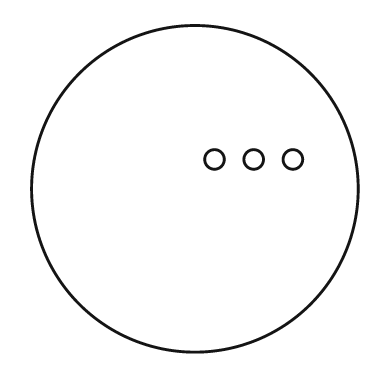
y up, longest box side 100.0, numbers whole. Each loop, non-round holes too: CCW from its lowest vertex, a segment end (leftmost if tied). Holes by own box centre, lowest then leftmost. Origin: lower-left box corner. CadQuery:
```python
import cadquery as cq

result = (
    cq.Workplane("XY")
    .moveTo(50.0, 50.0)
    .circle(50.0)
    .moveTo(56.0, 59.0)
    .circle(3.0)
    .moveTo(68.0, 59.0)
    .circle(3.0)
    .moveTo(80.0, 59.0)
    .circle(3.0)
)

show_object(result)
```